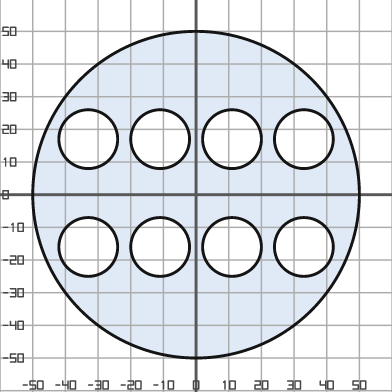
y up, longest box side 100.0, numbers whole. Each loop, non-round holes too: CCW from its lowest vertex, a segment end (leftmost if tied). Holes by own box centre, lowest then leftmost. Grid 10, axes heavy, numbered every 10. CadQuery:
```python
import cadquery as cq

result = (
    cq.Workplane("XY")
    .moveTo(0.0, 0.0)
    .circle(50.0)
    .moveTo(-33.0, -16.0)
    .circle(9.0)
    .moveTo(-11.0, -16.0)
    .circle(9.0)
    .moveTo(11.0, -16.0)
    .circle(9.0)
    .moveTo(33.0, -16.0)
    .circle(9.0)
    .moveTo(-33.0, 17.0)
    .circle(9.0)
    .moveTo(-11.0, 17.0)
    .circle(9.0)
    .moveTo(11.0, 17.0)
    .circle(9.0)
    .moveTo(33.0, 17.0)
    .circle(9.0)
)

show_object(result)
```